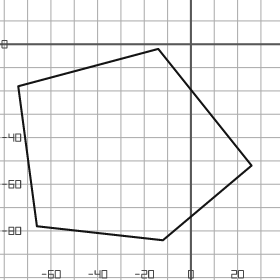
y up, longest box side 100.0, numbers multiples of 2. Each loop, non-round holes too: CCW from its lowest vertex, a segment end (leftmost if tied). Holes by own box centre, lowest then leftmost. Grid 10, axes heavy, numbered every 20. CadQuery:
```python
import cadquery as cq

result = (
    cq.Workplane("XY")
    .moveTo(-12.0, -84.0)
    .lineTo(26.0, -52.0)
    .lineTo(-14.0, -2.0)
    .lineTo(-74.0, -18.0)
    .lineTo(-66.0, -78.0)
    .close()
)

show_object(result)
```